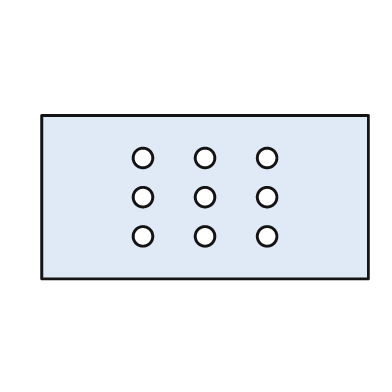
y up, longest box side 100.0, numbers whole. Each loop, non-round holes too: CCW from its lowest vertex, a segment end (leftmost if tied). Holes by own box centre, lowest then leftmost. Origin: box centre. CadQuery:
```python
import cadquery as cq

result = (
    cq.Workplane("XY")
    .moveTo(-50.0, -25.0)
    .lineTo(50.0, -25.0)
    .lineTo(50.0, 25.0)
    .lineTo(-50.0, 25.0)
    .close()
    .moveTo(-19.0, -12.0)
    .circle(3.0)
    .moveTo(0.0, -12.0)
    .circle(3.0)
    .moveTo(19.0, -12.0)
    .circle(3.0)
    .moveTo(-19.0, 0.0)
    .circle(3.0)
    .moveTo(0.0, 0.0)
    .circle(3.0)
    .moveTo(19.0, 0.0)
    .circle(3.0)
    .moveTo(-19.0, 12.0)
    .circle(3.0)
    .moveTo(0.0, 12.0)
    .circle(3.0)
    .moveTo(19.0, 12.0)
    .circle(3.0)
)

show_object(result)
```